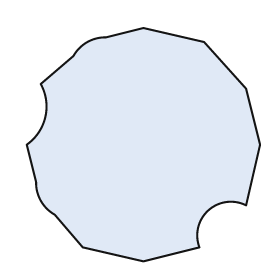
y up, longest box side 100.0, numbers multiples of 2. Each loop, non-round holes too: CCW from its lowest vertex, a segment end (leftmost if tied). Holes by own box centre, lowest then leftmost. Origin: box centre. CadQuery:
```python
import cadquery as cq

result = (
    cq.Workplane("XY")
    .moveTo(0.0, -50.0)
    .lineTo(24.0, -44.0)
    .threePointArc((28.0, -28.0), (44.0, -26.0))
    .lineTo(50.0, 0.0)
    .lineTo(44.0, 24.0)
    .lineTo(26.0, 44.0)
    .lineTo(0.0, 50.0)
    .lineTo(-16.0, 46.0)
    .threePointArc((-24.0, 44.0), (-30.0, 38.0))
    .lineTo(-44.0, 26.0)
    .threePointArc((-42.0, 12.0), (-50.0, 0.0))
    .lineTo(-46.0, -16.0)
    .threePointArc((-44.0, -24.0), (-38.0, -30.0))
    .lineTo(-26.0, -44.0)
    .close()
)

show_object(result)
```